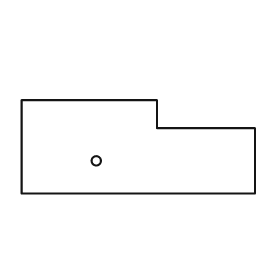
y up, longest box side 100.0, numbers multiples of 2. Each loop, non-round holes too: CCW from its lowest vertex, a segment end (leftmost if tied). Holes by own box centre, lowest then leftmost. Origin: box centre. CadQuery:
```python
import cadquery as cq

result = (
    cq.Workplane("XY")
    .moveTo(-50.0, -20.0)
    .lineTo(50.0, -20.0)
    .lineTo(50.0, 8.0)
    .lineTo(8.0, 8.0)
    .lineTo(8.0, 20.0)
    .lineTo(-50.0, 20.0)
    .close()
    .moveTo(-18.0, -6.0)
    .circle(2.0)
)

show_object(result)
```